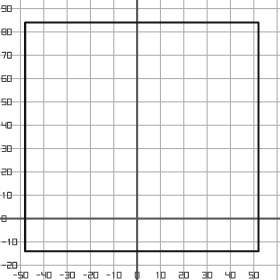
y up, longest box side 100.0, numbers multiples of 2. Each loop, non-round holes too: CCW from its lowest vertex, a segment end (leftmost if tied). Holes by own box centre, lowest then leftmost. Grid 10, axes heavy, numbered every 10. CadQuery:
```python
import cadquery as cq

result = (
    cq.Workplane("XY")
    .moveTo(-48.0, -14.0)
    .lineTo(52.0, -14.0)
    .lineTo(52.0, 84.0)
    .lineTo(-48.0, 84.0)
    .close()
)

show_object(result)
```